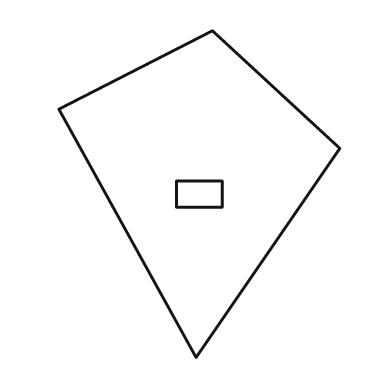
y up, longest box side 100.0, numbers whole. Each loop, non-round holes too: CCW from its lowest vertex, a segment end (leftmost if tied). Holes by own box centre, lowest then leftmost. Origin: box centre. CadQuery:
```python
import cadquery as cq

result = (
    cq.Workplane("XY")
    .moveTo(-1.0, -50.0)
    .lineTo(43.0, 14.0)
    .lineTo(4.0, 50.0)
    .lineTo(-43.0, 26.0)
    .close()
    .moveTo(-7.0, -4.0)
    .lineTo(7.0, -4.0)
    .lineTo(7.0, 4.0)
    .lineTo(-7.0, 4.0)
    .close()
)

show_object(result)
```